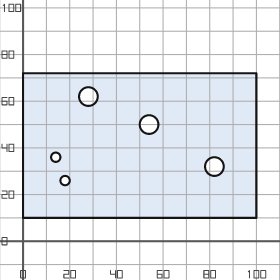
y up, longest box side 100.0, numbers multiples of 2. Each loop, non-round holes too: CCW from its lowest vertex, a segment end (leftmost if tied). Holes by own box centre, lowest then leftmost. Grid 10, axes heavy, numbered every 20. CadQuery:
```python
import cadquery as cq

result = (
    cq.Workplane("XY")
    .moveTo(0.0, 10.0)
    .lineTo(100.0, 10.0)
    .lineTo(100.0, 72.0)
    .lineTo(0.0, 72.0)
    .close()
    .moveTo(18.0, 26.0)
    .circle(2.0)
    .moveTo(82.0, 32.0)
    .circle(4.0)
    .moveTo(14.0, 36.0)
    .circle(2.0)
    .moveTo(54.0, 50.0)
    .circle(4.0)
    .moveTo(28.0, 62.0)
    .circle(4.0)
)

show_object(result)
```